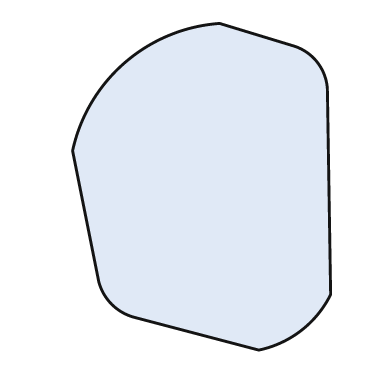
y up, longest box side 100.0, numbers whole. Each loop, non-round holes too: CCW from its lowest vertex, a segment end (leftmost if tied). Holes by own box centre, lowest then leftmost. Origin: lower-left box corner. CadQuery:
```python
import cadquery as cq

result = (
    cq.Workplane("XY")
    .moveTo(57.0, 0.0)
    .threePointArc((70.0, 6.0), (79.0, 17.0))
    .lineTo(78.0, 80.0)
    .threePointArc((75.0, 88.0), (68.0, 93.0))
    .lineTo(45.0, 100.0)
    .threePointArc((16.0, 88.0), (0.0, 61.0))
    .lineTo(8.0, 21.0)
    .threePointArc((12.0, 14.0), (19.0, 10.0))
    .close()
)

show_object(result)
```